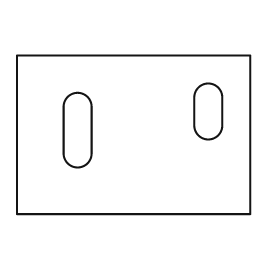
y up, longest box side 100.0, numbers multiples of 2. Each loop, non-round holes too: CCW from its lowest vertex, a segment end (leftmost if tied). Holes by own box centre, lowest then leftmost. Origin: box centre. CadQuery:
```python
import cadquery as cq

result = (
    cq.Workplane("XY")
    .moveTo(-50.0, -34.0)
    .lineTo(50.0, -34.0)
    .lineTo(50.0, 34.0)
    .lineTo(-50.0, 34.0)
    .close()
    .moveTo(-30.0, -8.0)
    .threePointArc((-24.0, -14.0), (-18.0, -8.0))
    .lineTo(-18.0, 12.0)
    .threePointArc((-24.0, 18.0), (-30.0, 12.0))
    .close()
    .moveTo(26.0, 4.0)
    .threePointArc((32.0, -2.0), (38.0, 4.0))
    .lineTo(38.0, 16.0)
    .threePointArc((32.0, 22.0), (26.0, 16.0))
    .close()
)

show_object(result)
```